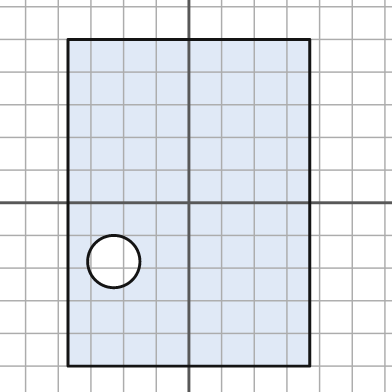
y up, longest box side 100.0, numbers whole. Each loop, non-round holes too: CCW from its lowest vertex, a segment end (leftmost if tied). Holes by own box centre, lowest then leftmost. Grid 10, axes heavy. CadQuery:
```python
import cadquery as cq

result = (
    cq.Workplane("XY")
    .moveTo(-37.0, -50.0)
    .lineTo(37.0, -50.0)
    .lineTo(37.0, 50.0)
    .lineTo(-37.0, 50.0)
    .close()
    .moveTo(-23.0, -18.0)
    .circle(8.0)
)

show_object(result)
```